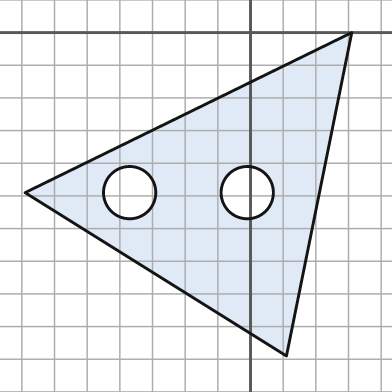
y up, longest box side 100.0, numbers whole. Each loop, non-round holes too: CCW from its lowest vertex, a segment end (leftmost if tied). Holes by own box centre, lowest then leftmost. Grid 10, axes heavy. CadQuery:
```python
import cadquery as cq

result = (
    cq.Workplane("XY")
    .moveTo(11.0, -99.0)
    .lineTo(31.0, 0.0)
    .lineTo(-69.0, -49.0)
    .close()
    .moveTo(-37.0, -49.0)
    .circle(8.0)
    .moveTo(-1.0, -49.0)
    .circle(8.0)
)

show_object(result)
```